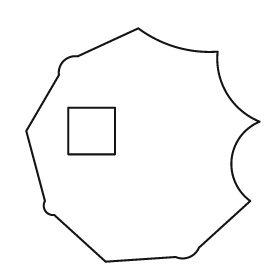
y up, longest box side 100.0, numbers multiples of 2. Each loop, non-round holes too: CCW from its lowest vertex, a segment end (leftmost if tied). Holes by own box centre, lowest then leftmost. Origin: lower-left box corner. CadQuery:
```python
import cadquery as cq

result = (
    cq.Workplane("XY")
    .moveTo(34.0, 0.0)
    .lineTo(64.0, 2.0)
    .threePointArc((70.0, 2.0), (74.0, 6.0))
    .lineTo(96.0, 26.0)
    .threePointArc((88.0, 44.0), (100.0, 60.0))
    .threePointArc((86.0, 72.0), (82.0, 90.0))
    .threePointArc((64.0, 92.0), (48.0, 100.0))
    .lineTo(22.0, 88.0)
    .threePointArc((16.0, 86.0), (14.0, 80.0))
    .lineTo(0.0, 56.0)
    .lineTo(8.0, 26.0)
    .threePointArc((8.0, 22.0), (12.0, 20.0))
    .close()
    .moveTo(18.0, 46.0)
    .lineTo(38.0, 46.0)
    .lineTo(38.0, 66.0)
    .lineTo(18.0, 66.0)
    .close()
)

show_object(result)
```